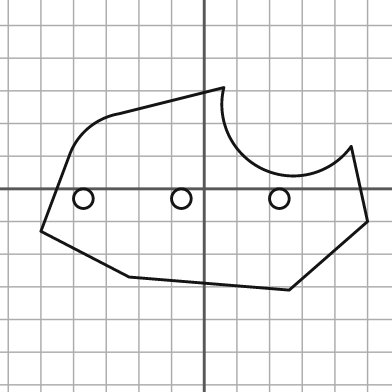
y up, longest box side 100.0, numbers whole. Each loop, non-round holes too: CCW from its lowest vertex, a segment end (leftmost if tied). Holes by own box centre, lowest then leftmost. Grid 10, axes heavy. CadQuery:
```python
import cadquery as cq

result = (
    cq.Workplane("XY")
    .moveTo(26.0, -31.0)
    .lineTo(50.0, -10.0)
    .lineTo(45.0, 13.0)
    .threePointArc((18.0, 6.0), (6.0, 31.0))
    .lineTo(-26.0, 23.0)
    .threePointArc((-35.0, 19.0), (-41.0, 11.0))
    .lineTo(-50.0, -13.0)
    .lineTo(-23.0, -27.0)
    .close()
    .moveTo(-37.0, -3.0)
    .circle(3.0)
    .moveTo(-7.0, -3.0)
    .circle(3.0)
    .moveTo(23.0, -3.0)
    .circle(3.0)
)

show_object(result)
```